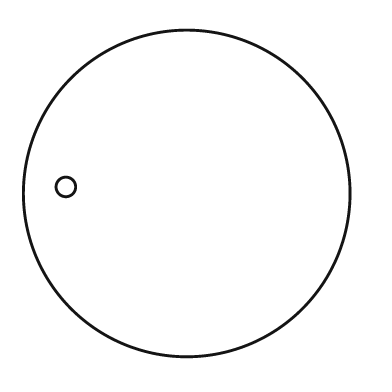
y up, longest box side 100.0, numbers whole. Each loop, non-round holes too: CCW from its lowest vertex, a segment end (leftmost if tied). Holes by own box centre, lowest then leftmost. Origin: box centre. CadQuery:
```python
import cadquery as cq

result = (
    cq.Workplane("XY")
    .moveTo(0.0, 0.0)
    .circle(50.0)
    .moveTo(-37.0, 2.0)
    .circle(3.0)
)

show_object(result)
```